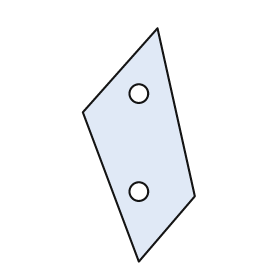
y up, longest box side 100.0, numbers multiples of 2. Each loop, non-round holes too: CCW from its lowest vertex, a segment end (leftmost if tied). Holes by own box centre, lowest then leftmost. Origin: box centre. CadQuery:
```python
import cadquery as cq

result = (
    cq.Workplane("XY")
    .moveTo(0.0, -50.0)
    .lineTo(24.0, -22.0)
    .lineTo(8.0, 50.0)
    .lineTo(-24.0, 14.0)
    .close()
    .moveTo(0.0, -20.0)
    .circle(4.0)
    .moveTo(0.0, 22.0)
    .circle(4.0)
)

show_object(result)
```